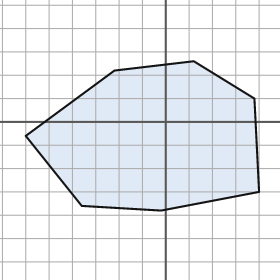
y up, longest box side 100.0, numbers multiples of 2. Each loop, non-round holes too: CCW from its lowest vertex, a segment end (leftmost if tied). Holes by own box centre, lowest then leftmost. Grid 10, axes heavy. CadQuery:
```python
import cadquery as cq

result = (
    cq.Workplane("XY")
    .moveTo(-2.0, -38.0)
    .lineTo(40.0, -30.0)
    .lineTo(38.0, 10.0)
    .lineTo(12.0, 26.0)
    .lineTo(-22.0, 22.0)
    .lineTo(-60.0, -6.0)
    .lineTo(-36.0, -36.0)
    .close()
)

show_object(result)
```